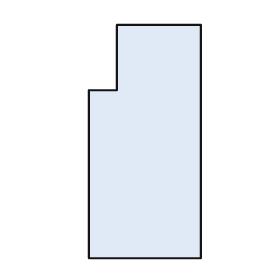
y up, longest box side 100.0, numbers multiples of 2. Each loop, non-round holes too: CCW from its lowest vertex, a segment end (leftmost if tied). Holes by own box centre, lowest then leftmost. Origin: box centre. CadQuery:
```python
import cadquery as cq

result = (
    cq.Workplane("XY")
    .moveTo(-24.0, -50.0)
    .lineTo(24.0, -50.0)
    .lineTo(24.0, 50.0)
    .lineTo(-12.0, 50.0)
    .lineTo(-12.0, 22.0)
    .lineTo(-24.0, 22.0)
    .close()
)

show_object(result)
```